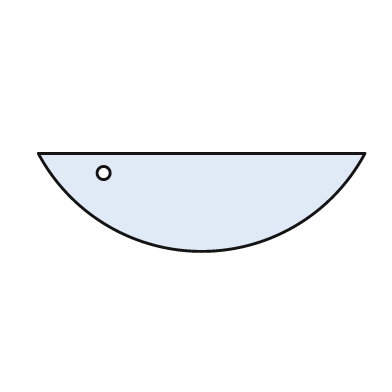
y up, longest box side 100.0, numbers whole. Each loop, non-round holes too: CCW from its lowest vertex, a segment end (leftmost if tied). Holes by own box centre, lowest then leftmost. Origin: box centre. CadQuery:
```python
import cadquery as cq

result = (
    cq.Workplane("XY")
    .moveTo(-50.0, 15.0)
    .threePointArc((0.0, -15.0), (50.0, 15.0))
    .close()
    .moveTo(-30.0, 9.0)
    .circle(2.0)
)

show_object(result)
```